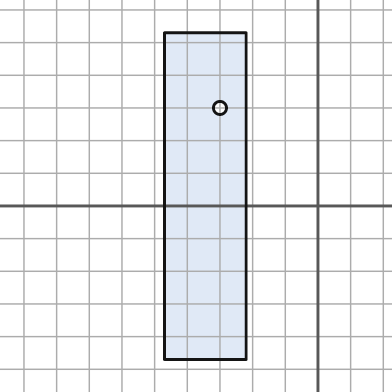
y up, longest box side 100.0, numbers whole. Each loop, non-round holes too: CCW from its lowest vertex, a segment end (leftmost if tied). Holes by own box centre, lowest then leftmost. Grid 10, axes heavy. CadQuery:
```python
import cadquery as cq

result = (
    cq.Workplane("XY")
    .moveTo(-47.0, -47.0)
    .lineTo(-22.0, -47.0)
    .lineTo(-22.0, 53.0)
    .lineTo(-47.0, 53.0)
    .close()
    .moveTo(-30.0, 30.0)
    .circle(2.0)
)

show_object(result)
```